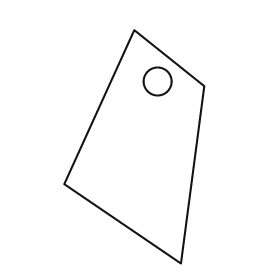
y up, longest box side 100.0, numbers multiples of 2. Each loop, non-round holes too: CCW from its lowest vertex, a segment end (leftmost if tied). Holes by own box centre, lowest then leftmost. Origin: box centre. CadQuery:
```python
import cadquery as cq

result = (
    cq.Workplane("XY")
    .moveTo(20.0, -50.0)
    .lineTo(30.0, 26.0)
    .lineTo(0.0, 50.0)
    .lineTo(-30.0, -16.0)
    .close()
    .moveTo(10.0, 28.0)
    .circle(6.0)
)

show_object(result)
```